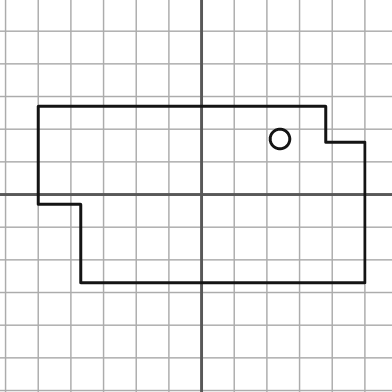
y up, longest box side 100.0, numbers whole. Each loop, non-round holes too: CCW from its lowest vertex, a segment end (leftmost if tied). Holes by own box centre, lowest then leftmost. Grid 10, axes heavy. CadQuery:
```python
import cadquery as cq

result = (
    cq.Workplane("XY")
    .moveTo(-37.0, -27.0)
    .lineTo(50.0, -27.0)
    .lineTo(50.0, 16.0)
    .lineTo(38.0, 16.0)
    .lineTo(38.0, 27.0)
    .lineTo(-50.0, 27.0)
    .lineTo(-50.0, -3.0)
    .lineTo(-37.0, -3.0)
    .close()
    .moveTo(24.0, 17.0)
    .circle(3.0)
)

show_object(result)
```